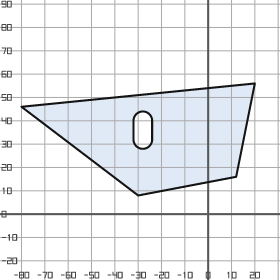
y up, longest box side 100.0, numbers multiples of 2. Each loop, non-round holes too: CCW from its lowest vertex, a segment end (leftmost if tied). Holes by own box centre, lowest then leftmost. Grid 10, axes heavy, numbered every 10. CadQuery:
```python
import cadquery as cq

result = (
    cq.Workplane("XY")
    .moveTo(-30.0, 8.0)
    .lineTo(12.0, 16.0)
    .lineTo(20.0, 56.0)
    .lineTo(-80.0, 46.0)
    .close()
    .moveTo(-32.0, 32.0)
    .threePointArc((-28.0, 28.0), (-24.0, 32.0))
    .lineTo(-24.0, 40.0)
    .threePointArc((-28.0, 44.0), (-32.0, 40.0))
    .close()
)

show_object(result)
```